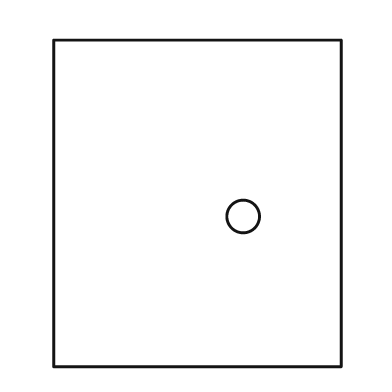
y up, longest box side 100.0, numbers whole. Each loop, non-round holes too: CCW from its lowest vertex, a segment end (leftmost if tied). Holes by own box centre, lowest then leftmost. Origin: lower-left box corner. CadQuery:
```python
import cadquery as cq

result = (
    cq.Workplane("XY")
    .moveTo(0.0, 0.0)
    .lineTo(88.0, 0.0)
    .lineTo(88.0, 100.0)
    .lineTo(0.0, 100.0)
    .close()
    .moveTo(58.0, 46.0)
    .circle(5.0)
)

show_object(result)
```